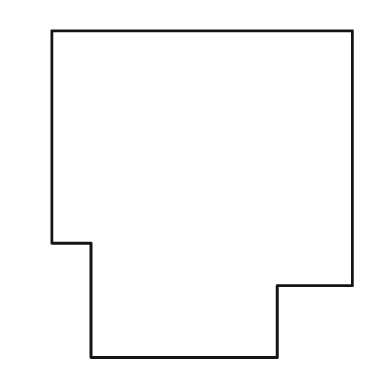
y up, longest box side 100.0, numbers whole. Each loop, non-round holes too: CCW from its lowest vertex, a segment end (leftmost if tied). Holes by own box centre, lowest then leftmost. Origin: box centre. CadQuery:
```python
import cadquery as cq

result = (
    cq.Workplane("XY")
    .moveTo(-34.0, -50.0)
    .lineTo(23.0, -50.0)
    .lineTo(23.0, -28.0)
    .lineTo(46.0, -28.0)
    .lineTo(46.0, 50.0)
    .lineTo(-46.0, 50.0)
    .lineTo(-46.0, -15.0)
    .lineTo(-34.0, -15.0)
    .close()
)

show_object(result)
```